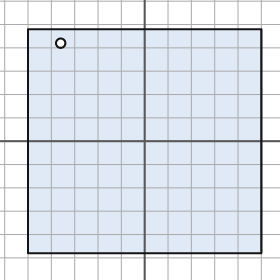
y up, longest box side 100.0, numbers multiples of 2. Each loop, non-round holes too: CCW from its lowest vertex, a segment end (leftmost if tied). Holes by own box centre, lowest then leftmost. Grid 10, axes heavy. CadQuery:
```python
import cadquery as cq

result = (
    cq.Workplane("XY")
    .moveTo(-50.0, -48.0)
    .lineTo(50.0, -48.0)
    .lineTo(50.0, 48.0)
    .lineTo(-50.0, 48.0)
    .close()
    .moveTo(-36.0, 42.0)
    .circle(2.0)
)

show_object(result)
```